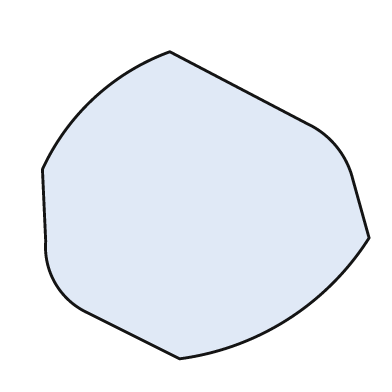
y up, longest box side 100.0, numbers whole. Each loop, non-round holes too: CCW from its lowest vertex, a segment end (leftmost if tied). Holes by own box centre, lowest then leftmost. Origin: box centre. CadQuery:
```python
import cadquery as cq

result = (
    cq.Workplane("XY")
    .moveTo(-8.0, -47.0)
    .threePointArc((25.0, -35.0), (50.0, -10.0))
    .lineTo(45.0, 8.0)
    .threePointArc((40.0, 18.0), (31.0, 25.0))
    .lineTo(-11.0, 47.0)
    .threePointArc((-34.0, 33.0), (-50.0, 11.0))
    .lineTo(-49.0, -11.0)
    .threePointArc((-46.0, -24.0), (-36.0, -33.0))
    .close()
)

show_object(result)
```